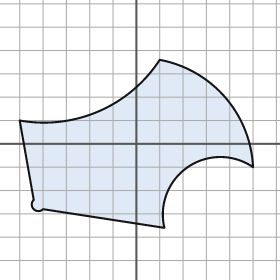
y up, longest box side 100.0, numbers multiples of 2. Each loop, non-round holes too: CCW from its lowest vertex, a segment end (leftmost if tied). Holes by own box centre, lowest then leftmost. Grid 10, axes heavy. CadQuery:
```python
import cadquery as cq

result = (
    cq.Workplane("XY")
    .moveTo(12.0, -36.0)
    .threePointArc((22.0, -10.0), (50.0, -10.0))
    .threePointArc((38.0, 20.0), (10.0, 36.0))
    .threePointArc((-16.0, 14.0), (-50.0, 10.0))
    .lineTo(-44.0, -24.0)
    .threePointArc((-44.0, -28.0), (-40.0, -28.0))
    .close()
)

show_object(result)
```